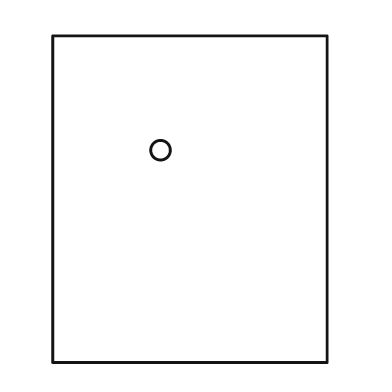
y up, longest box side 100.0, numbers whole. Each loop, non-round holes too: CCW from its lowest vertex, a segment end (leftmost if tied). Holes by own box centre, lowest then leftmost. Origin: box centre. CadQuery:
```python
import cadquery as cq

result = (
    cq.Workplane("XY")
    .moveTo(-42.0, -50.0)
    .lineTo(42.0, -50.0)
    .lineTo(42.0, 50.0)
    .lineTo(-42.0, 50.0)
    .close()
    .moveTo(-9.0, 15.0)
    .circle(3.0)
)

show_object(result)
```